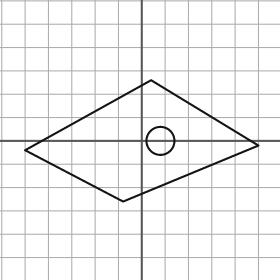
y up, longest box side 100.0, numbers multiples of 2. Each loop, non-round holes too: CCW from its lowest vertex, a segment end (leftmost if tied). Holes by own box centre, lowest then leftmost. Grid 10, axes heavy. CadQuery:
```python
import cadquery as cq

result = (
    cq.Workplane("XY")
    .moveTo(-8.0, -26.0)
    .lineTo(50.0, -2.0)
    .lineTo(4.0, 26.0)
    .lineTo(-50.0, -4.0)
    .close()
    .moveTo(8.0, 0.0)
    .circle(6.0)
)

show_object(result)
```